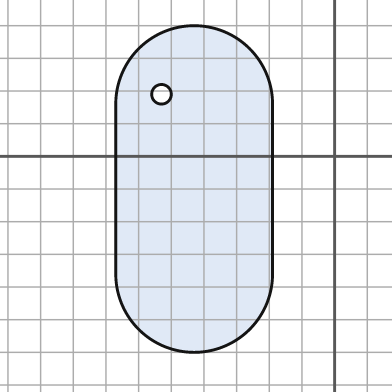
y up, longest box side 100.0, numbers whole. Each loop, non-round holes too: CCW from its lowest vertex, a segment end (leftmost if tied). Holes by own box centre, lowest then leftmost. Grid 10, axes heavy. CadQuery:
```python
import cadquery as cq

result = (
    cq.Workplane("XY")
    .moveTo(-67.0, -36.0)
    .threePointArc((-43.0, -60.0), (-19.0, -36.0))
    .lineTo(-19.0, 16.0)
    .threePointArc((-43.0, 40.0), (-67.0, 16.0))
    .close()
    .moveTo(-53.0, 19.0)
    .circle(3.0)
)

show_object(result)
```